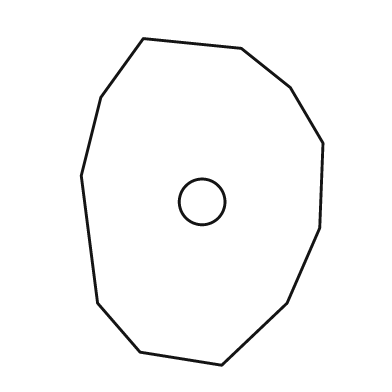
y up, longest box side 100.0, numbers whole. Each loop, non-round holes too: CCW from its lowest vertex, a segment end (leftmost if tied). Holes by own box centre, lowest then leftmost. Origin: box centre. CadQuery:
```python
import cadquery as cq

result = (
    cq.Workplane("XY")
    .moveTo(6.0, -50.0)
    .lineTo(26.0, -31.0)
    .lineTo(36.0, -8.0)
    .lineTo(37.0, 18.0)
    .lineTo(27.0, 35.0)
    .lineTo(12.0, 47.0)
    .lineTo(-18.0, 50.0)
    .lineTo(-31.0, 32.0)
    .lineTo(-37.0, 8.0)
    .lineTo(-32.0, -31.0)
    .lineTo(-19.0, -46.0)
    .close()
    .moveTo(0.0, 0.0)
    .circle(7.0)
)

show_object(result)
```